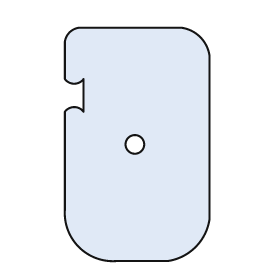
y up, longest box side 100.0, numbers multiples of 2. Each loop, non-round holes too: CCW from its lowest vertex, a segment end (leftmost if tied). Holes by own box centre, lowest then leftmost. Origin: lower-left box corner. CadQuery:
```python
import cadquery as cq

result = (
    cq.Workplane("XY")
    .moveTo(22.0, 0.0)
    .lineTo(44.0, 0.0)
    .threePointArc((56.0, 6.0), (62.0, 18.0))
    .lineTo(62.0, 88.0)
    .threePointArc((58.0, 96.0), (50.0, 100.0))
    .lineTo(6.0, 100.0)
    .threePointArc((2.0, 98.0), (0.0, 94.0))
    .lineTo(0.0, 78.0)
    .threePointArc((4.0, 76.0), (8.0, 78.0))
    .lineTo(8.0, 64.0)
    .threePointArc((4.0, 66.0), (0.0, 64.0))
    .lineTo(0.0, 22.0)
    .threePointArc((6.0, 6.0), (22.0, 0.0))
    .close()
    .moveTo(30.0, 50.0)
    .circle(4.0)
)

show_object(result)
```